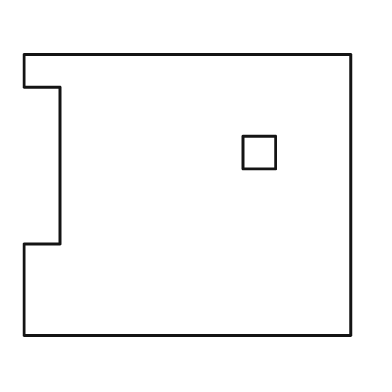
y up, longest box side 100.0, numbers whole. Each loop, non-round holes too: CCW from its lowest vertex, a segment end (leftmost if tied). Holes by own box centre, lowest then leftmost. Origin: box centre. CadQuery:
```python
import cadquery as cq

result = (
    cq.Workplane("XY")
    .moveTo(-50.0, -43.0)
    .lineTo(50.0, -43.0)
    .lineTo(50.0, 43.0)
    .lineTo(-50.0, 43.0)
    .lineTo(-50.0, 33.0)
    .lineTo(-39.0, 33.0)
    .lineTo(-39.0, -15.0)
    .lineTo(-50.0, -15.0)
    .close()
    .moveTo(17.0, 8.0)
    .lineTo(27.0, 8.0)
    .lineTo(27.0, 18.0)
    .lineTo(17.0, 18.0)
    .close()
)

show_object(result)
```